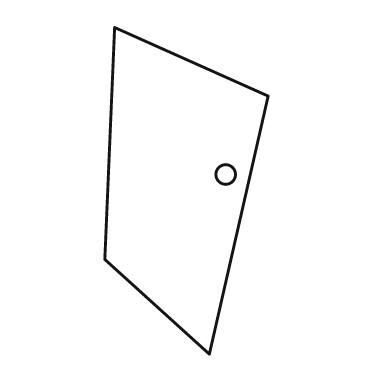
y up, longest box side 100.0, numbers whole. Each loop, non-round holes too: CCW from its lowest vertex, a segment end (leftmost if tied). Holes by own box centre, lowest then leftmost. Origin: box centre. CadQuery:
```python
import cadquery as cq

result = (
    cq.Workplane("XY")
    .moveTo(7.0, -50.0)
    .lineTo(25.0, 29.0)
    .lineTo(-22.0, 50.0)
    .lineTo(-25.0, -21.0)
    .close()
    .moveTo(12.0, 5.0)
    .circle(3.0)
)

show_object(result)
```